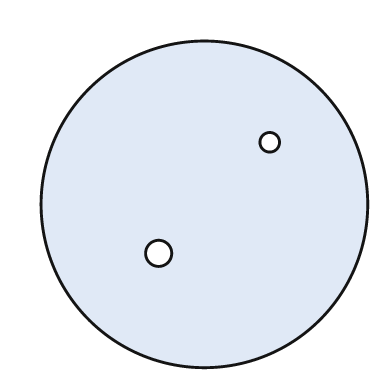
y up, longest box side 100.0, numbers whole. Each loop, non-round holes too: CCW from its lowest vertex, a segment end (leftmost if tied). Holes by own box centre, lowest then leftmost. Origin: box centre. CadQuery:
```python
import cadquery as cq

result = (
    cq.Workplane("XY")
    .moveTo(0.0, 0.0)
    .circle(50.0)
    .moveTo(-14.0, -15.0)
    .circle(4.0)
    .moveTo(20.0, 19.0)
    .circle(3.0)
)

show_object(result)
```